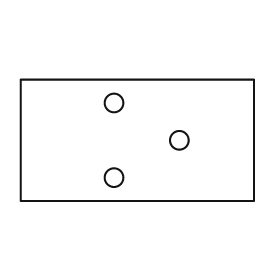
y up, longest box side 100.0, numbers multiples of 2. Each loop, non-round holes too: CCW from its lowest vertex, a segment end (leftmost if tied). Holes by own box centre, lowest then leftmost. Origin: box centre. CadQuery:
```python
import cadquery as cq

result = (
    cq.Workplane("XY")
    .moveTo(-50.0, -26.0)
    .lineTo(50.0, -26.0)
    .lineTo(50.0, 26.0)
    .lineTo(-50.0, 26.0)
    .close()
    .moveTo(-10.0, -16.0)
    .circle(4.0)
    .moveTo(18.0, 0.0)
    .circle(4.0)
    .moveTo(-10.0, 16.0)
    .circle(4.0)
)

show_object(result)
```